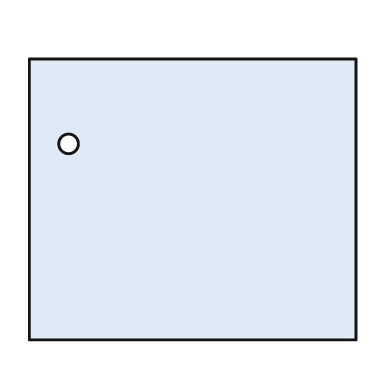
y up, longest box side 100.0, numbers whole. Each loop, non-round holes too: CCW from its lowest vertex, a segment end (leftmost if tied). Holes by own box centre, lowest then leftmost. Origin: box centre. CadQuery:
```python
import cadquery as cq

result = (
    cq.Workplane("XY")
    .moveTo(-50.0, -43.0)
    .lineTo(50.0, -43.0)
    .lineTo(50.0, 43.0)
    .lineTo(-50.0, 43.0)
    .close()
    .moveTo(-38.0, 17.0)
    .circle(3.0)
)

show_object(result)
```